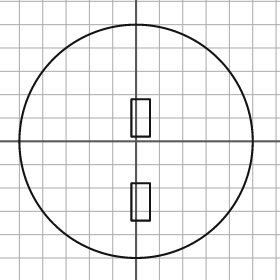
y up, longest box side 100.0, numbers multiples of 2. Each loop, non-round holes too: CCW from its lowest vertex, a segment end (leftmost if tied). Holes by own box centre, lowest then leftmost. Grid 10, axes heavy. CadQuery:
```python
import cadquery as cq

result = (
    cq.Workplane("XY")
    .moveTo(0.0, 0.0)
    .circle(50.0)
    .moveTo(-2.0, -34.0)
    .lineTo(6.0, -34.0)
    .lineTo(6.0, -18.0)
    .lineTo(-2.0, -18.0)
    .close()
    .moveTo(-2.0, 2.0)
    .lineTo(6.0, 2.0)
    .lineTo(6.0, 18.0)
    .lineTo(-2.0, 18.0)
    .close()
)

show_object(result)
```